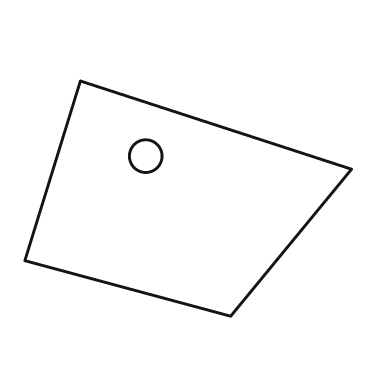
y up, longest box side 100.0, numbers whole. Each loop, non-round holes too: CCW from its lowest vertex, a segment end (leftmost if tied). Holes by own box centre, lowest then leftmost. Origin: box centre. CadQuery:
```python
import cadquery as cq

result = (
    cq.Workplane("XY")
    .moveTo(13.0, -36.0)
    .lineTo(50.0, 9.0)
    .lineTo(-33.0, 36.0)
    .lineTo(-50.0, -19.0)
    .close()
    .moveTo(-13.0, 13.0)
    .circle(5.0)
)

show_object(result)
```